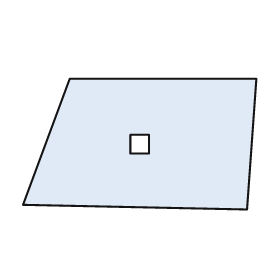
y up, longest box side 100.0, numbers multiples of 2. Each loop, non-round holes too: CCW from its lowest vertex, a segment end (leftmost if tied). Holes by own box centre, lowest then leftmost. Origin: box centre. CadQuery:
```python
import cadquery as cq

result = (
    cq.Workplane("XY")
    .moveTo(46.0, -28.0)
    .lineTo(50.0, 28.0)
    .lineTo(-30.0, 28.0)
    .lineTo(-50.0, -26.0)
    .close()
    .moveTo(-4.0, -4.0)
    .lineTo(4.0, -4.0)
    .lineTo(4.0, 4.0)
    .lineTo(-4.0, 4.0)
    .close()
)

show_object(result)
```